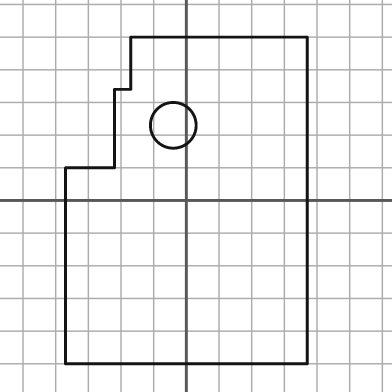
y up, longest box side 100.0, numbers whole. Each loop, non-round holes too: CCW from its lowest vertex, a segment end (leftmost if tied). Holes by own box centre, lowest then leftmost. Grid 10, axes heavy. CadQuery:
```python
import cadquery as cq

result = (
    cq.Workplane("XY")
    .moveTo(-37.0, -50.0)
    .lineTo(37.0, -50.0)
    .lineTo(37.0, 50.0)
    .lineTo(-17.0, 50.0)
    .lineTo(-17.0, 34.0)
    .lineTo(-22.0, 34.0)
    .lineTo(-22.0, 10.0)
    .lineTo(-37.0, 10.0)
    .close()
    .moveTo(-4.0, 23.0)
    .circle(7.0)
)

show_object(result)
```